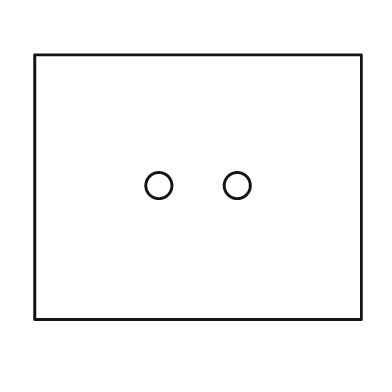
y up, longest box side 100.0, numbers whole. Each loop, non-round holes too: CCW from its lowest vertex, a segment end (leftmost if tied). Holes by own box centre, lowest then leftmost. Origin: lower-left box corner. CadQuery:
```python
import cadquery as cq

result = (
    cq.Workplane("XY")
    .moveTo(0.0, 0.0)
    .lineTo(100.0, 0.0)
    .lineTo(100.0, 81.0)
    .lineTo(0.0, 81.0)
    .close()
    .moveTo(38.0, 41.0)
    .circle(4.0)
    .moveTo(62.0, 41.0)
    .circle(4.0)
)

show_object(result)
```